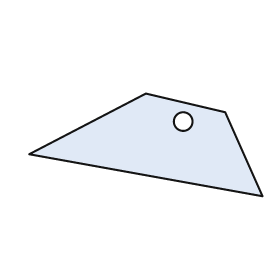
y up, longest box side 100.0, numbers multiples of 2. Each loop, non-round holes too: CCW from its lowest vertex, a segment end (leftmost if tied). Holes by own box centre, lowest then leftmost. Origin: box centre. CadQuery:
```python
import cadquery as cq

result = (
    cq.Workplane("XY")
    .moveTo(50.0, -22.0)
    .lineTo(34.0, 14.0)
    .lineTo(0.0, 22.0)
    .lineTo(-50.0, -4.0)
    .close()
    .moveTo(16.0, 10.0)
    .circle(4.0)
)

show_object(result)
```